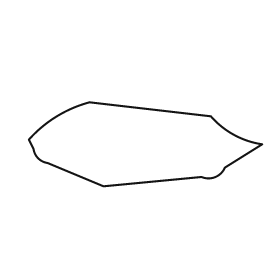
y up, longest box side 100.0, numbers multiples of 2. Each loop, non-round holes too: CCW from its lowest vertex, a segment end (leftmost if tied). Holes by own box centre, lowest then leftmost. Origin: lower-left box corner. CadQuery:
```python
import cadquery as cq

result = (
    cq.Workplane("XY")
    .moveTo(32.0, 0.0)
    .lineTo(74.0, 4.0)
    .threePointArc((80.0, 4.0), (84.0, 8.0))
    .lineTo(100.0, 18.0)
    .threePointArc((88.0, 22.0), (78.0, 30.0))
    .lineTo(26.0, 36.0)
    .threePointArc((12.0, 30.0), (0.0, 20.0))
    .lineTo(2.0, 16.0)
    .threePointArc((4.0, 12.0), (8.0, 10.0))
    .close()
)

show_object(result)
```